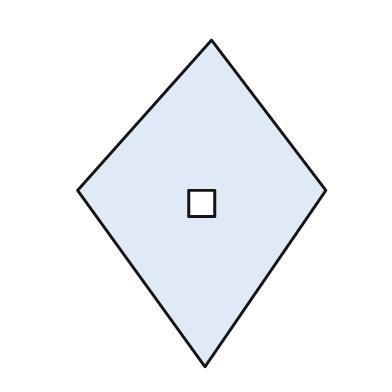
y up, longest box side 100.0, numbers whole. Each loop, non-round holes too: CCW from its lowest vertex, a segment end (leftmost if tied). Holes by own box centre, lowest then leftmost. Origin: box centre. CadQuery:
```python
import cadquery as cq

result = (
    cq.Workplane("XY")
    .moveTo(1.0, -50.0)
    .lineTo(38.0, 4.0)
    .lineTo(3.0, 50.0)
    .lineTo(-38.0, 4.0)
    .close()
    .moveTo(-4.0, -4.0)
    .lineTo(4.0, -4.0)
    .lineTo(4.0, 4.0)
    .lineTo(-4.0, 4.0)
    .close()
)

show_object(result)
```